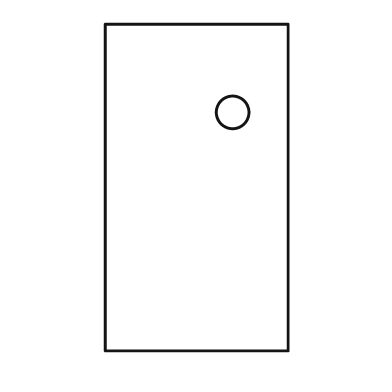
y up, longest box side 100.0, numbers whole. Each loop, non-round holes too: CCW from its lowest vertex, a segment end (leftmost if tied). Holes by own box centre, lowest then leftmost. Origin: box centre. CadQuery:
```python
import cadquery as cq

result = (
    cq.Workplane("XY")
    .moveTo(-28.0, -50.0)
    .lineTo(28.0, -50.0)
    .lineTo(28.0, 50.0)
    .lineTo(-28.0, 50.0)
    .close()
    .moveTo(11.0, 23.0)
    .circle(5.0)
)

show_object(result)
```